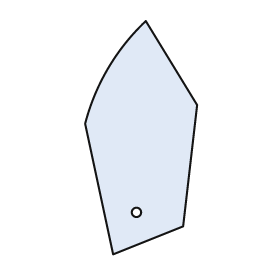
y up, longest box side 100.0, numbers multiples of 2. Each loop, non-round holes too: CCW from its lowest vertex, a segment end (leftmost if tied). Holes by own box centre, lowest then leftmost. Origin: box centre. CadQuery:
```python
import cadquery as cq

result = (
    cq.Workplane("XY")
    .moveTo(-12.0, -50.0)
    .lineTo(18.0, -38.0)
    .lineTo(24.0, 14.0)
    .lineTo(2.0, 50.0)
    .threePointArc((-14.0, 30.0), (-24.0, 6.0))
    .close()
    .moveTo(-2.0, -32.0)
    .circle(2.0)
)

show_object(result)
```